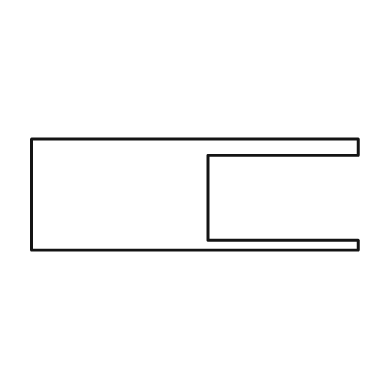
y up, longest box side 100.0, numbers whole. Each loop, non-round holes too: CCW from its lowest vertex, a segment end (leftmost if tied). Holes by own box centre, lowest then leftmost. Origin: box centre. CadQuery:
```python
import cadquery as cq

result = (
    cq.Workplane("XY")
    .moveTo(-50.0, -17.0)
    .lineTo(50.0, -17.0)
    .lineTo(50.0, -14.0)
    .lineTo(4.0, -14.0)
    .lineTo(4.0, 12.0)
    .lineTo(50.0, 12.0)
    .lineTo(50.0, 17.0)
    .lineTo(-50.0, 17.0)
    .close()
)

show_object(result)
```